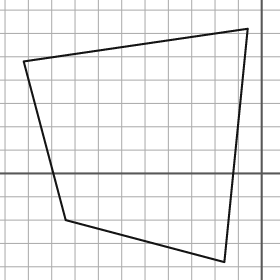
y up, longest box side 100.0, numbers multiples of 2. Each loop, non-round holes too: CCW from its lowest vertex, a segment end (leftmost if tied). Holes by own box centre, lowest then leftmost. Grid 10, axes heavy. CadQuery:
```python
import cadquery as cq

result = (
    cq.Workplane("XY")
    .moveTo(-16.0, -38.0)
    .lineTo(-6.0, 62.0)
    .lineTo(-102.0, 48.0)
    .lineTo(-84.0, -20.0)
    .close()
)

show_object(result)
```